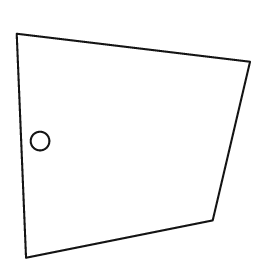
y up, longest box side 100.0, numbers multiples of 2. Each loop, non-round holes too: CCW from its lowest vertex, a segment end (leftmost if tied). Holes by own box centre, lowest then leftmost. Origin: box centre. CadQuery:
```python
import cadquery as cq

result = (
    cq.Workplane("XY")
    .moveTo(-46.0, -48.0)
    .lineTo(34.0, -32.0)
    .lineTo(50.0, 36.0)
    .lineTo(-50.0, 48.0)
    .close()
    .moveTo(-40.0, 2.0)
    .circle(4.0)
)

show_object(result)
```